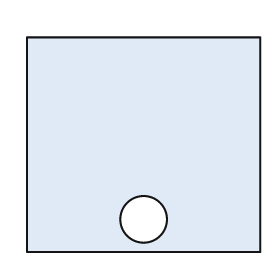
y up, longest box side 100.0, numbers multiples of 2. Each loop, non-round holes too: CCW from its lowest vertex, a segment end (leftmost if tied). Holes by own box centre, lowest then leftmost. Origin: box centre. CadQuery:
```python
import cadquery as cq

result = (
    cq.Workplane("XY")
    .moveTo(-50.0, -46.0)
    .lineTo(50.0, -46.0)
    .lineTo(50.0, 46.0)
    .lineTo(-50.0, 46.0)
    .close()
    .moveTo(0.0, -32.0)
    .circle(10.0)
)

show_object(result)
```